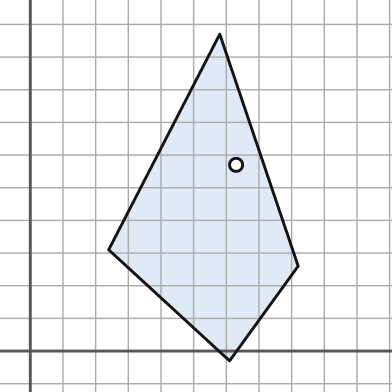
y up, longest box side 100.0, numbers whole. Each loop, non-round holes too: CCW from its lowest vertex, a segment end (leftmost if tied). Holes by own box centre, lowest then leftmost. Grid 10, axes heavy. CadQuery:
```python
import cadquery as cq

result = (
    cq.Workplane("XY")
    .moveTo(61.0, -3.0)
    .lineTo(82.0, 26.0)
    .lineTo(58.0, 97.0)
    .lineTo(24.0, 31.0)
    .close()
    .moveTo(63.0, 57.0)
    .circle(2.0)
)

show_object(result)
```